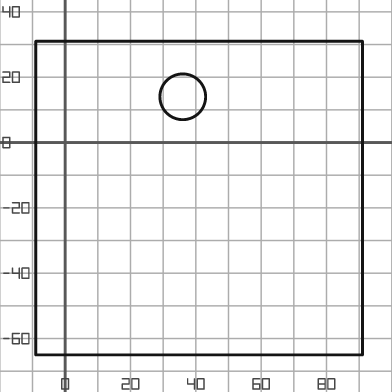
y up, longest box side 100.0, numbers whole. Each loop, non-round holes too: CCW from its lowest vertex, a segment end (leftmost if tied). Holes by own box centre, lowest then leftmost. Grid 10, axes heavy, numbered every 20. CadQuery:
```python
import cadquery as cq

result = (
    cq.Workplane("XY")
    .moveTo(-9.0, -65.0)
    .lineTo(91.0, -65.0)
    .lineTo(91.0, 31.0)
    .lineTo(-9.0, 31.0)
    .close()
    .moveTo(36.0, 14.0)
    .circle(7.0)
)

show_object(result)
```